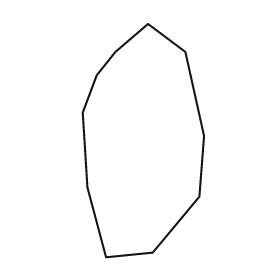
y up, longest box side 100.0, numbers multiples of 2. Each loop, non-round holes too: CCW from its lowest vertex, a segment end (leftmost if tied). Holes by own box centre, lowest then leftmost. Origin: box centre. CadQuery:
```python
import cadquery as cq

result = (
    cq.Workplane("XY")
    .moveTo(-16.0, -50.0)
    .lineTo(4.0, -48.0)
    .lineTo(24.0, -24.0)
    .lineTo(26.0, 2.0)
    .lineTo(18.0, 38.0)
    .lineTo(2.0, 50.0)
    .lineTo(-12.0, 38.0)
    .lineTo(-20.0, 28.0)
    .lineTo(-26.0, 12.0)
    .lineTo(-24.0, -20.0)
    .close()
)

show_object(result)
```